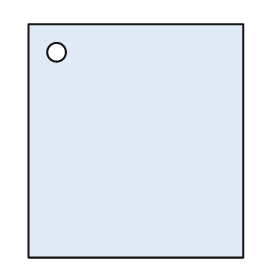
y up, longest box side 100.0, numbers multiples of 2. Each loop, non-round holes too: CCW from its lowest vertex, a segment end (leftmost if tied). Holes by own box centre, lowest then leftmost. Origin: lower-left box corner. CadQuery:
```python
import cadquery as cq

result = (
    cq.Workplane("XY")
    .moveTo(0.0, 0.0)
    .lineTo(92.0, 0.0)
    .lineTo(92.0, 100.0)
    .lineTo(0.0, 100.0)
    .close()
    .moveTo(12.0, 88.0)
    .circle(4.0)
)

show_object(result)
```